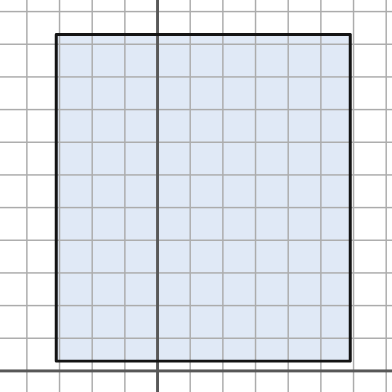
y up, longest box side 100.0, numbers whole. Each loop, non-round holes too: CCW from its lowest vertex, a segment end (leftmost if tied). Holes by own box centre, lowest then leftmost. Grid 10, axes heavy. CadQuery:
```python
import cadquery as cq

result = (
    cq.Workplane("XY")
    .moveTo(-31.0, 3.0)
    .lineTo(59.0, 3.0)
    .lineTo(59.0, 103.0)
    .lineTo(-31.0, 103.0)
    .close()
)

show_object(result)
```